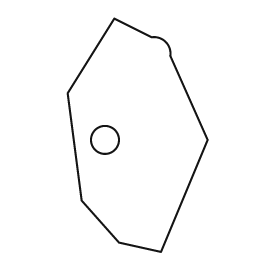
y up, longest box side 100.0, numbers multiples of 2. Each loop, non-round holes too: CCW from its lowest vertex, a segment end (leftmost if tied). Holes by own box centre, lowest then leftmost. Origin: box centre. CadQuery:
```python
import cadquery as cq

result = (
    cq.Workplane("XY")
    .moveTo(10.0, -50.0)
    .lineTo(30.0, -2.0)
    .lineTo(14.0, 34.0)
    .threePointArc((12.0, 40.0), (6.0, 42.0))
    .lineTo(-10.0, 50.0)
    .lineTo(-30.0, 18.0)
    .lineTo(-24.0, -28.0)
    .lineTo(-8.0, -46.0)
    .close()
    .moveTo(-14.0, -2.0)
    .circle(6.0)
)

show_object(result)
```